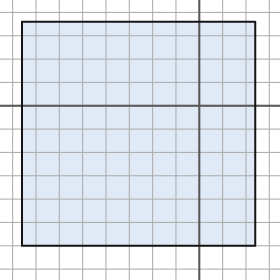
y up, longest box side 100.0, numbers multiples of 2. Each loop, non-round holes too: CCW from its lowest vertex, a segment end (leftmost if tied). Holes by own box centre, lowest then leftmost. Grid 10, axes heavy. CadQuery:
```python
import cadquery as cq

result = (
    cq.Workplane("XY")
    .moveTo(-76.0, -60.0)
    .lineTo(24.0, -60.0)
    .lineTo(24.0, 36.0)
    .lineTo(-76.0, 36.0)
    .close()
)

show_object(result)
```